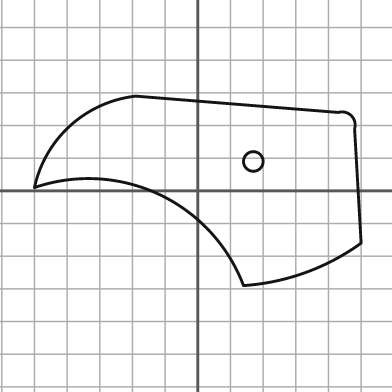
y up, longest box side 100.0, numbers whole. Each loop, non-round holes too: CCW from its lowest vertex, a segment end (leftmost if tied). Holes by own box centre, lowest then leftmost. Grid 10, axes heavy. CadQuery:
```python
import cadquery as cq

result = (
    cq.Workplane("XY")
    .moveTo(14.0, -29.0)
    .threePointArc((33.0, -25.0), (50.0, -16.0))
    .lineTo(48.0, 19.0)
    .threePointArc((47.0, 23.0), (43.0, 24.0))
    .lineTo(-19.0, 29.0)
    .threePointArc((-39.0, 20.0), (-50.0, 1.0))
    .threePointArc((-12.0, -1.0), (14.0, -29.0))
    .close()
    .moveTo(17.0, 9.0)
    .circle(3.0)
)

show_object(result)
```